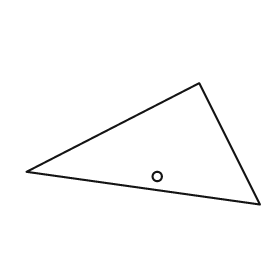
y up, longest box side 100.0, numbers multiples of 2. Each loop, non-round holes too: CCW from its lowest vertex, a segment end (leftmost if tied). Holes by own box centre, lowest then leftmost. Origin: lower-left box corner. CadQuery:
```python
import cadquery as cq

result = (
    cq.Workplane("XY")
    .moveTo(100.0, 0.0)
    .lineTo(74.0, 52.0)
    .lineTo(0.0, 14.0)
    .close()
    .moveTo(56.0, 12.0)
    .circle(2.0)
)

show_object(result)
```